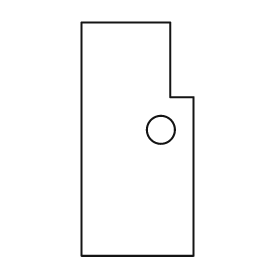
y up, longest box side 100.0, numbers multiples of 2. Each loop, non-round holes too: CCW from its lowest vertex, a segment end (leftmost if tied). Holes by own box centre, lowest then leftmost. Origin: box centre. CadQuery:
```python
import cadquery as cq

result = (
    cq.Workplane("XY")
    .moveTo(-24.0, -50.0)
    .lineTo(24.0, -50.0)
    .lineTo(24.0, 18.0)
    .lineTo(14.0, 18.0)
    .lineTo(14.0, 50.0)
    .lineTo(-24.0, 50.0)
    .close()
    .moveTo(10.0, 4.0)
    .circle(6.0)
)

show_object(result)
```